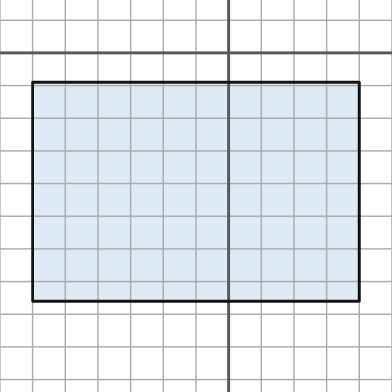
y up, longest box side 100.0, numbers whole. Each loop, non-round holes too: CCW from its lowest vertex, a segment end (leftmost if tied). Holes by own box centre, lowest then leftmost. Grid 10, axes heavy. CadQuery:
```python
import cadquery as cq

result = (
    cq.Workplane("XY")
    .moveTo(-60.0, -76.0)
    .lineTo(40.0, -76.0)
    .lineTo(40.0, -9.0)
    .lineTo(-60.0, -9.0)
    .close()
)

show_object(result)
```